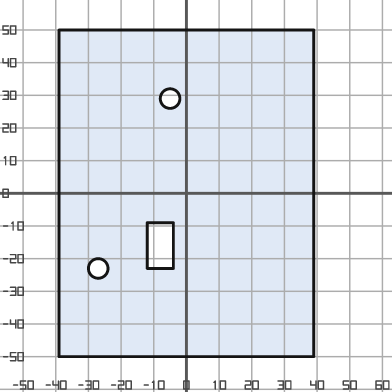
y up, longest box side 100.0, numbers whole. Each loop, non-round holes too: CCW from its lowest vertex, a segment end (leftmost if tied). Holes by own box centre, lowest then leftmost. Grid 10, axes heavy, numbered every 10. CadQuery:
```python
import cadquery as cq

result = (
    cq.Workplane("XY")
    .moveTo(-39.0, -50.0)
    .lineTo(39.0, -50.0)
    .lineTo(39.0, 50.0)
    .lineTo(-39.0, 50.0)
    .close()
    .moveTo(-27.0, -23.0)
    .circle(3.0)
    .moveTo(-12.0, -23.0)
    .lineTo(-4.0, -23.0)
    .lineTo(-4.0, -9.0)
    .lineTo(-12.0, -9.0)
    .close()
    .moveTo(-5.0, 29.0)
    .circle(3.0)
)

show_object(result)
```